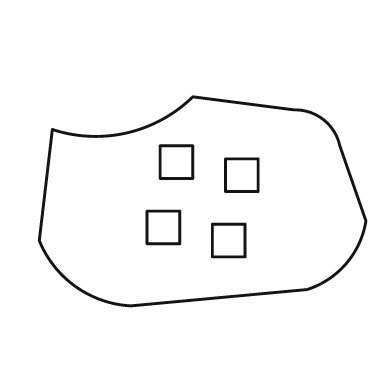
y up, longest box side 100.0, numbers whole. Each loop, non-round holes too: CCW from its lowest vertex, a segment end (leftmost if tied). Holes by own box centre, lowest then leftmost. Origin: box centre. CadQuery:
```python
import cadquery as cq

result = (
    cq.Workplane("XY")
    .moveTo(-22.0, -32.0)
    .lineTo(32.0, -27.0)
    .threePointArc((44.0, -19.0), (50.0, -6.0))
    .lineTo(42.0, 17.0)
    .threePointArc((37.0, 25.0), (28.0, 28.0))
    .lineTo(-3.0, 32.0)
    .threePointArc((-23.0, 21.0), (-46.0, 22.0))
    .lineTo(-50.0, -12.0)
    .threePointArc((-39.0, -26.0), (-22.0, -32.0))
    .close()
    .moveTo(3.0, -17.0)
    .lineTo(13.0, -17.0)
    .lineTo(13.0, -7.0)
    .lineTo(3.0, -7.0)
    .close()
    .moveTo(-17.0, -13.0)
    .lineTo(-7.0, -13.0)
    .lineTo(-7.0, -3.0)
    .lineTo(-17.0, -3.0)
    .close()
    .moveTo(7.0, 3.0)
    .lineTo(17.0, 3.0)
    .lineTo(17.0, 13.0)
    .lineTo(7.0, 13.0)
    .close()
    .moveTo(-13.0, 7.0)
    .lineTo(-3.0, 7.0)
    .lineTo(-3.0, 17.0)
    .lineTo(-13.0, 17.0)
    .close()
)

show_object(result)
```